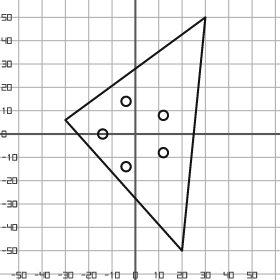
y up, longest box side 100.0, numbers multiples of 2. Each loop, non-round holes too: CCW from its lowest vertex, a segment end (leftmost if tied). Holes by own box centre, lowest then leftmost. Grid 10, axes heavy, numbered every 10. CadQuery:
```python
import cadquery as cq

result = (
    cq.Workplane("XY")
    .moveTo(20.0, -50.0)
    .lineTo(30.0, 50.0)
    .lineTo(-30.0, 6.0)
    .close()
    .moveTo(-4.0, -14.0)
    .circle(2.0)
    .moveTo(12.0, -8.0)
    .circle(2.0)
    .moveTo(-14.0, 0.0)
    .circle(2.0)
    .moveTo(12.0, 8.0)
    .circle(2.0)
    .moveTo(-4.0, 14.0)
    .circle(2.0)
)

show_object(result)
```